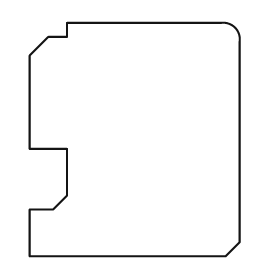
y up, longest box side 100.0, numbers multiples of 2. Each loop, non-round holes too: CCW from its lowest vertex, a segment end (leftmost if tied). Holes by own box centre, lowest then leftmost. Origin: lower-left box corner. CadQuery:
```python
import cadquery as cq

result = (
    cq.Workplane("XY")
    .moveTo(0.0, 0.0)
    .lineTo(84.0, 0.0)
    .lineTo(90.0, 6.0)
    .lineTo(90.0, 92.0)
    .threePointArc((88.0, 98.0), (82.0, 100.0))
    .lineTo(16.0, 100.0)
    .lineTo(16.0, 94.0)
    .lineTo(8.0, 94.0)
    .lineTo(0.0, 86.0)
    .lineTo(0.0, 46.0)
    .lineTo(16.0, 46.0)
    .lineTo(16.0, 26.0)
    .lineTo(10.0, 20.0)
    .lineTo(0.0, 20.0)
    .close()
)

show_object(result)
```